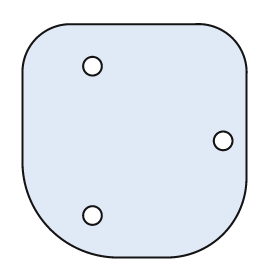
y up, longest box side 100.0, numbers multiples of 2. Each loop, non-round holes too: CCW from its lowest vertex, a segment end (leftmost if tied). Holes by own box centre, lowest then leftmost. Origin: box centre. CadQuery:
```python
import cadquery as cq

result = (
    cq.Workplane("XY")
    .moveTo(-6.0, -50.0)
    .lineTo(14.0, -50.0)
    .threePointArc((38.0, -40.0), (48.0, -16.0))
    .lineTo(48.0, 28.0)
    .threePointArc((42.0, 44.0), (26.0, 50.0))
    .lineTo(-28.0, 50.0)
    .threePointArc((-42.0, 44.0), (-48.0, 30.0))
    .lineTo(-48.0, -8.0)
    .threePointArc((-36.0, -38.0), (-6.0, -50.0))
    .close()
    .moveTo(-18.0, -32.0)
    .circle(4.0)
    .moveTo(38.0, 0.0)
    .circle(4.0)
    .moveTo(-18.0, 32.0)
    .circle(4.0)
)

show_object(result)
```